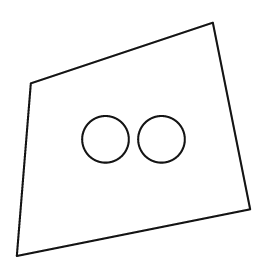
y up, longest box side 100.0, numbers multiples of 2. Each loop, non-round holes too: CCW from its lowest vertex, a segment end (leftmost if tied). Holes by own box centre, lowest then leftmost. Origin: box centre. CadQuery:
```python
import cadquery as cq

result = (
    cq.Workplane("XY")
    .moveTo(-50.0, -50.0)
    .lineTo(50.0, -30.0)
    .lineTo(34.0, 50.0)
    .lineTo(-44.0, 24.0)
    .close()
    .moveTo(-12.0, 0.0)
    .circle(10.0)
    .moveTo(12.0, 0.0)
    .circle(10.0)
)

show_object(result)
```